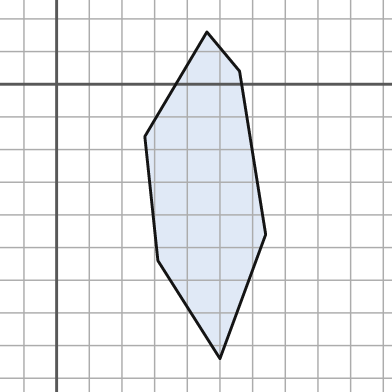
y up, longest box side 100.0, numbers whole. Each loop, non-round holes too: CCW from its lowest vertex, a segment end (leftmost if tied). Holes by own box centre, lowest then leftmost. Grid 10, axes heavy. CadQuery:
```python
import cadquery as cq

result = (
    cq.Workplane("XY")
    .moveTo(50.0, -84.0)
    .lineTo(64.0, -46.0)
    .lineTo(56.0, 4.0)
    .lineTo(46.0, 16.0)
    .lineTo(27.0, -16.0)
    .lineTo(31.0, -54.0)
    .close()
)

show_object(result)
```